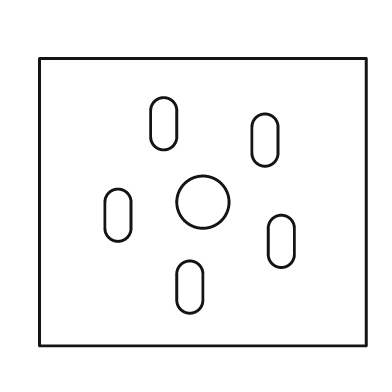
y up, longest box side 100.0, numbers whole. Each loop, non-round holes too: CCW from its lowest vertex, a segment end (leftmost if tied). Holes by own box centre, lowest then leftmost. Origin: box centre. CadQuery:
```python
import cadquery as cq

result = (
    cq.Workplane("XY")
    .moveTo(-50.0, -44.0)
    .lineTo(50.0, -44.0)
    .lineTo(50.0, 44.0)
    .lineTo(-50.0, 44.0)
    .close()
    .moveTo(-8.0, -30.0)
    .threePointArc((-4.0, -34.0), (0.0, -30.0))
    .lineTo(0.0, -22.0)
    .threePointArc((-4.0, -18.0), (-8.0, -22.0))
    .close()
    .moveTo(20.0, -16.0)
    .threePointArc((24.0, -20.0), (28.0, -16.0))
    .lineTo(28.0, -8.0)
    .threePointArc((24.0, -4.0), (20.0, -8.0))
    .close()
    .moveTo(-30.0, -8.0)
    .threePointArc((-26.0, -12.0), (-22.0, -8.0))
    .lineTo(-22.0, 0.0)
    .threePointArc((-26.0, 4.0), (-30.0, 0.0))
    .close()
    .moveTo(0.0, 0.0)
    .circle(8.0)
    .moveTo(15.0, 15.0)
    .threePointArc((19.0, 11.0), (23.0, 15.0))
    .lineTo(23.0, 23.0)
    .threePointArc((19.0, 27.0), (15.0, 23.0))
    .close()
    .moveTo(-16.0, 20.0)
    .threePointArc((-12.0, 16.0), (-8.0, 20.0))
    .lineTo(-8.0, 28.0)
    .threePointArc((-12.0, 32.0), (-16.0, 28.0))
    .close()
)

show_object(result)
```